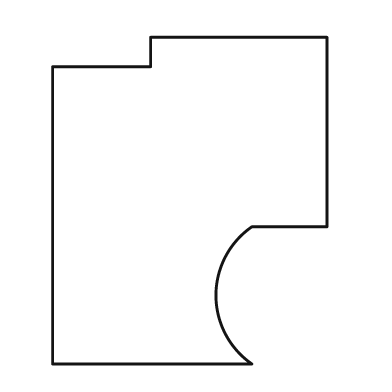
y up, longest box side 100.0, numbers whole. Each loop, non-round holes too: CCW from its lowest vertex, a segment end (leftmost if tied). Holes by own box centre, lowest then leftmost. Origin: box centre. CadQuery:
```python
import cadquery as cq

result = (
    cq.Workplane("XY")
    .moveTo(-42.0, -50.0)
    .lineTo(19.0, -50.0)
    .threePointArc((8.0, -29.0), (19.0, -8.0))
    .lineTo(42.0, -8.0)
    .lineTo(42.0, 50.0)
    .lineTo(-12.0, 50.0)
    .lineTo(-12.0, 41.0)
    .lineTo(-42.0, 41.0)
    .close()
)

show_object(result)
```